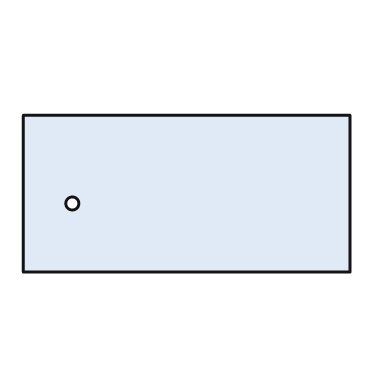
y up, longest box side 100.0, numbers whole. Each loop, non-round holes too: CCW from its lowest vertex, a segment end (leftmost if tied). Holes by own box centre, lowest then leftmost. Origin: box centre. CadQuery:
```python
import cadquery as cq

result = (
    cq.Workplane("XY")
    .moveTo(-50.0, -24.0)
    .lineTo(50.0, -24.0)
    .lineTo(50.0, 24.0)
    .lineTo(-50.0, 24.0)
    .close()
    .moveTo(-35.0, -3.0)
    .circle(2.0)
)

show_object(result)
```